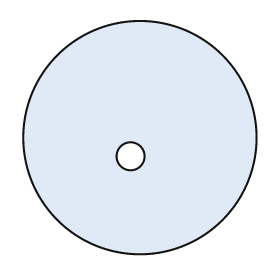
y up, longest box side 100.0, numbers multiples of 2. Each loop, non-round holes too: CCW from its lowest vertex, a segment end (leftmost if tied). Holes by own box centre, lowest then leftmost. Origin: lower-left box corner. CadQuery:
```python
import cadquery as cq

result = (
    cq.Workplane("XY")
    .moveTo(50.0, 50.0)
    .circle(50.0)
    .moveTo(46.0, 42.0)
    .circle(6.0)
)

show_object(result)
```